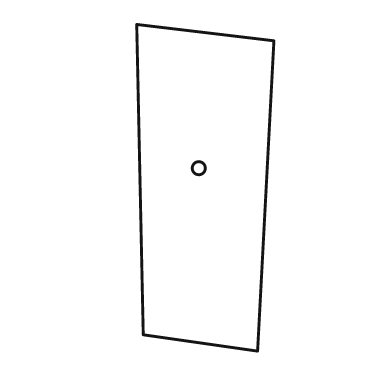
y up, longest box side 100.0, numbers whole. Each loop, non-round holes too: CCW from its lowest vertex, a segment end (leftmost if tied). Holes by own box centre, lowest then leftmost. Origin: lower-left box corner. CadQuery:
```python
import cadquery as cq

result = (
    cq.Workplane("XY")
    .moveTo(37.0, 0.0)
    .lineTo(42.0, 95.0)
    .lineTo(0.0, 100.0)
    .lineTo(2.0, 5.0)
    .close()
    .moveTo(19.0, 56.0)
    .circle(2.0)
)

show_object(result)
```